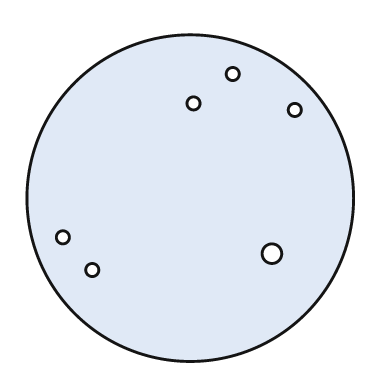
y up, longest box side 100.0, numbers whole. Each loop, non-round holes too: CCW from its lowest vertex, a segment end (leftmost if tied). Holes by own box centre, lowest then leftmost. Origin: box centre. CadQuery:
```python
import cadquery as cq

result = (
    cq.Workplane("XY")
    .moveTo(0.0, 0.0)
    .circle(50.0)
    .moveTo(-30.0, -22.0)
    .circle(2.0)
    .moveTo(25.0, -17.0)
    .circle(3.0)
    .moveTo(-39.0, -12.0)
    .circle(2.0)
    .moveTo(32.0, 27.0)
    .circle(2.0)
    .moveTo(1.0, 29.0)
    .circle(2.0)
    .moveTo(13.0, 38.0)
    .circle(2.0)
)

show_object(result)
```